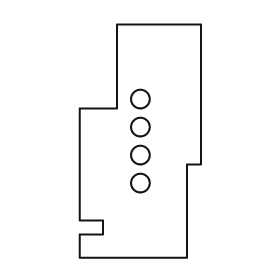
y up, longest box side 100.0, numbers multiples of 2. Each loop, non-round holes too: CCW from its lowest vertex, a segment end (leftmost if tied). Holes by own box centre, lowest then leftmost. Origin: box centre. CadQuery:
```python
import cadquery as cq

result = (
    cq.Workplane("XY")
    .moveTo(-26.0, -50.0)
    .lineTo(20.0, -50.0)
    .lineTo(20.0, -10.0)
    .lineTo(26.0, -10.0)
    .lineTo(26.0, 50.0)
    .lineTo(-10.0, 50.0)
    .lineTo(-10.0, 14.0)
    .lineTo(-26.0, 14.0)
    .lineTo(-26.0, -34.0)
    .lineTo(-16.0, -34.0)
    .lineTo(-16.0, -40.0)
    .lineTo(-26.0, -40.0)
    .close()
    .moveTo(0.0, -18.0)
    .circle(4.0)
    .moveTo(0.0, -6.0)
    .circle(4.0)
    .moveTo(0.0, 6.0)
    .circle(4.0)
    .moveTo(0.0, 18.0)
    .circle(4.0)
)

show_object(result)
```